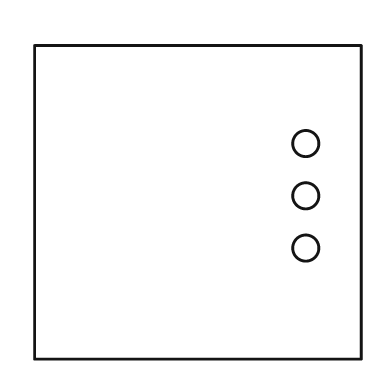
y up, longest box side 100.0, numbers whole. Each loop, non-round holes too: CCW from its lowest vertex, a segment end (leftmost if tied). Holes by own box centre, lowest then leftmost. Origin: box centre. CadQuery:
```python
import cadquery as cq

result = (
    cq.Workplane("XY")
    .moveTo(-50.0, -48.0)
    .lineTo(50.0, -48.0)
    .lineTo(50.0, 48.0)
    .lineTo(-50.0, 48.0)
    .close()
    .moveTo(33.0, -14.0)
    .circle(4.0)
    .moveTo(33.0, 2.0)
    .circle(4.0)
    .moveTo(33.0, 18.0)
    .circle(4.0)
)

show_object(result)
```